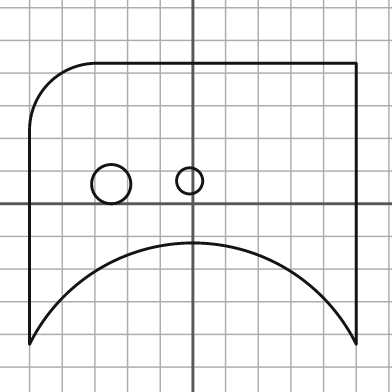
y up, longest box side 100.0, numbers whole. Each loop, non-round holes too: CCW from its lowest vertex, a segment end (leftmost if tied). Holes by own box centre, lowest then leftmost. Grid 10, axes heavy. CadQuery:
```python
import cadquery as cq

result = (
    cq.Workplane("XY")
    .moveTo(-50.0, -43.0)
    .threePointArc((0.0, -12.0), (50.0, -43.0))
    .lineTo(50.0, 43.0)
    .lineTo(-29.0, 43.0)
    .threePointArc((-44.0, 37.0), (-50.0, 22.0))
    .close()
    .moveTo(-25.0, 6.0)
    .circle(6.0)
    .moveTo(-1.0, 7.0)
    .circle(4.0)
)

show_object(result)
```